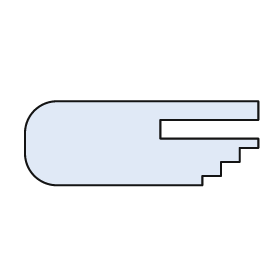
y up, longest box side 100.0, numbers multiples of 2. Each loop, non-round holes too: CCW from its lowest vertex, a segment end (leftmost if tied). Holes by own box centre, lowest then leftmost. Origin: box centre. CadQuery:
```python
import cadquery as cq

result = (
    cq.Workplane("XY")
    .moveTo(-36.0, -18.0)
    .lineTo(26.0, -18.0)
    .lineTo(26.0, -14.0)
    .lineTo(34.0, -14.0)
    .lineTo(34.0, -8.0)
    .lineTo(42.0, -8.0)
    .lineTo(42.0, -2.0)
    .lineTo(50.0, -2.0)
    .lineTo(50.0, 2.0)
    .lineTo(8.0, 2.0)
    .lineTo(8.0, 10.0)
    .lineTo(50.0, 10.0)
    .lineTo(50.0, 18.0)
    .lineTo(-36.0, 18.0)
    .threePointArc((-46.0, 14.0), (-50.0, 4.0))
    .lineTo(-50.0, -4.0)
    .threePointArc((-46.0, -14.0), (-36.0, -18.0))
    .close()
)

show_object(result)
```